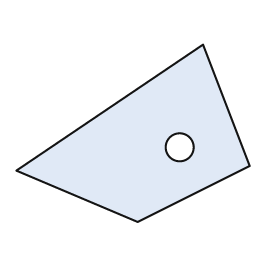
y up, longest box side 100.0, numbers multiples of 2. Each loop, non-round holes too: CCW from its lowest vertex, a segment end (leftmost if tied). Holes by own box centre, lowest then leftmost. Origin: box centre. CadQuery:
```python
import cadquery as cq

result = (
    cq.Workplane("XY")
    .moveTo(2.0, -38.0)
    .lineTo(50.0, -14.0)
    .lineTo(30.0, 38.0)
    .lineTo(-50.0, -16.0)
    .close()
    .moveTo(20.0, -6.0)
    .circle(6.0)
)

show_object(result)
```